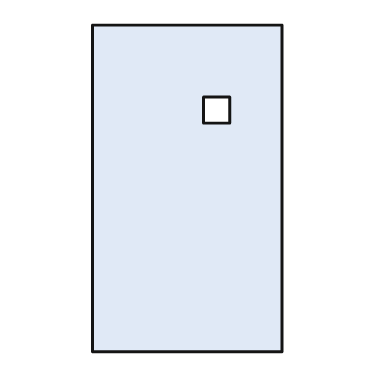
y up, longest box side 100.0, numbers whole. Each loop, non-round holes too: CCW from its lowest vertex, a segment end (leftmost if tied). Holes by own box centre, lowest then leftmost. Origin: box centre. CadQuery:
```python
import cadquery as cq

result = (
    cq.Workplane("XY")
    .moveTo(-29.0, -50.0)
    .lineTo(29.0, -50.0)
    .lineTo(29.0, 50.0)
    .lineTo(-29.0, 50.0)
    .close()
    .moveTo(5.0, 20.0)
    .lineTo(13.0, 20.0)
    .lineTo(13.0, 28.0)
    .lineTo(5.0, 28.0)
    .close()
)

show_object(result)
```